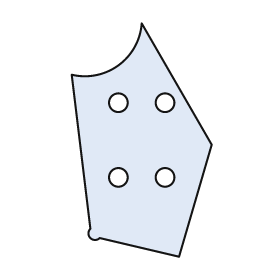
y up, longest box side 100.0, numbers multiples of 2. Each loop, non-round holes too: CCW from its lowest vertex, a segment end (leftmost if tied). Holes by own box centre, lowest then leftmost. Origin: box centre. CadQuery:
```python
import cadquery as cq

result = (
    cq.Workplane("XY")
    .moveTo(16.0, -50.0)
    .lineTo(30.0, -2.0)
    .lineTo(0.0, 50.0)
    .threePointArc((-10.0, 32.0), (-30.0, 28.0))
    .lineTo(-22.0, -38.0)
    .threePointArc((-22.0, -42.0), (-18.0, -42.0))
    .close()
    .moveTo(-10.0, -16.0)
    .circle(4.0)
    .moveTo(10.0, -16.0)
    .circle(4.0)
    .moveTo(-10.0, 16.0)
    .circle(4.0)
    .moveTo(10.0, 16.0)
    .circle(4.0)
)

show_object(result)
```